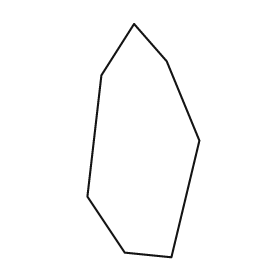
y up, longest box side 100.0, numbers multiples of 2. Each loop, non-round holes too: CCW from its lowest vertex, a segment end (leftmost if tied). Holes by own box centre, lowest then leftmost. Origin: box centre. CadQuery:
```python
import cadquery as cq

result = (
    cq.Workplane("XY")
    .moveTo(12.0, -50.0)
    .lineTo(24.0, 0.0)
    .lineTo(10.0, 34.0)
    .lineTo(-4.0, 50.0)
    .lineTo(-18.0, 28.0)
    .lineTo(-24.0, -24.0)
    .lineTo(-8.0, -48.0)
    .close()
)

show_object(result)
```